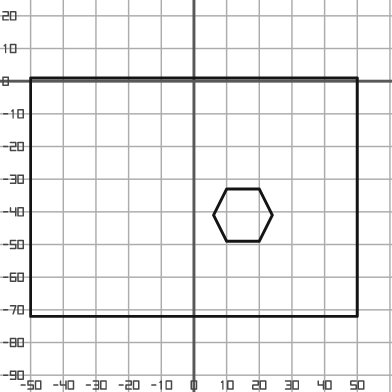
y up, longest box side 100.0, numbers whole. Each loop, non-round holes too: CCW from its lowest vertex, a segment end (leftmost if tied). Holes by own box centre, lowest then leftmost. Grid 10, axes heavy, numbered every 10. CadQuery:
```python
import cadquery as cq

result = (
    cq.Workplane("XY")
    .moveTo(-50.0, -72.0)
    .lineTo(50.0, -72.0)
    .lineTo(50.0, 1.0)
    .lineTo(-50.0, 1.0)
    .close()
    .moveTo(10.0, -49.0)
    .lineTo(20.0, -49.0)
    .lineTo(24.0, -41.0)
    .lineTo(20.0, -33.0)
    .lineTo(10.0, -33.0)
    .lineTo(6.0, -41.0)
    .close()
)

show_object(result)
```